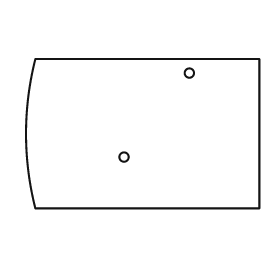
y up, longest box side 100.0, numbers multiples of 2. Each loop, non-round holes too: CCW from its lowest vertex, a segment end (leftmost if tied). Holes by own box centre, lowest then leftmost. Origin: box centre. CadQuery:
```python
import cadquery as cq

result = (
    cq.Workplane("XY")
    .moveTo(-46.0, -32.0)
    .lineTo(50.0, -32.0)
    .lineTo(50.0, 32.0)
    .lineTo(-46.0, 32.0)
    .threePointArc((-50.0, 0.0), (-46.0, -32.0))
    .close()
    .moveTo(-8.0, -10.0)
    .circle(2.0)
    .moveTo(20.0, 26.0)
    .circle(2.0)
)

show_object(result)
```